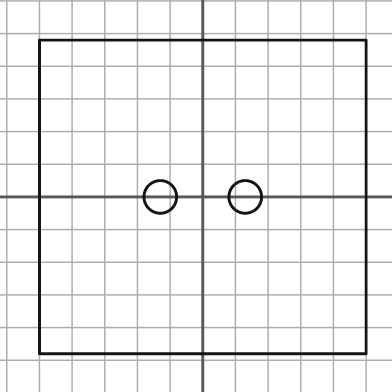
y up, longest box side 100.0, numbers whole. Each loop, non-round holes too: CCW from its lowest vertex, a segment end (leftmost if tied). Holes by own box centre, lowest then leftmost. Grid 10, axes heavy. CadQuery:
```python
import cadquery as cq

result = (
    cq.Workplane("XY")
    .moveTo(-50.0, -48.0)
    .lineTo(50.0, -48.0)
    .lineTo(50.0, 48.0)
    .lineTo(-50.0, 48.0)
    .close()
    .moveTo(-13.0, 0.0)
    .circle(5.0)
    .moveTo(13.0, 0.0)
    .circle(5.0)
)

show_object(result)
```